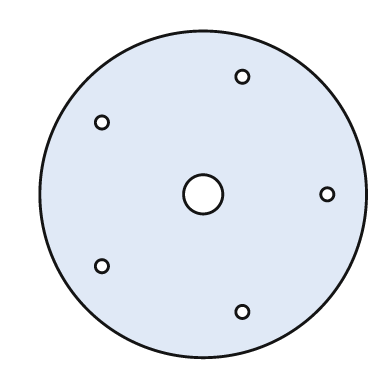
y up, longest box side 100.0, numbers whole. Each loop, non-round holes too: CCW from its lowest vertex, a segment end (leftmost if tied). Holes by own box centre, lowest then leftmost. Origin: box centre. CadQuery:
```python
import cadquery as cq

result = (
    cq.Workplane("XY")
    .moveTo(0.0, 0.0)
    .circle(50.0)
    .moveTo(12.0, -36.0)
    .circle(2.0)
    .moveTo(-31.0, -22.0)
    .circle(2.0)
    .moveTo(0.0, 0.0)
    .circle(6.0)
    .moveTo(38.0, 0.0)
    .circle(2.0)
    .moveTo(-31.0, 22.0)
    .circle(2.0)
    .moveTo(12.0, 36.0)
    .circle(2.0)
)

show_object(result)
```